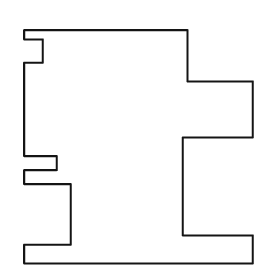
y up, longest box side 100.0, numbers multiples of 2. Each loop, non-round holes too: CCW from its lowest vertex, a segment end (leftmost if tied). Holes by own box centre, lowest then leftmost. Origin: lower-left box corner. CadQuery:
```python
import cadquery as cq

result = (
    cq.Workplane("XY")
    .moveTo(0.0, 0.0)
    .lineTo(98.0, 0.0)
    .lineTo(98.0, 12.0)
    .lineTo(68.0, 12.0)
    .lineTo(68.0, 54.0)
    .lineTo(98.0, 54.0)
    .lineTo(98.0, 78.0)
    .lineTo(70.0, 78.0)
    .lineTo(70.0, 100.0)
    .lineTo(0.0, 100.0)
    .lineTo(0.0, 96.0)
    .lineTo(8.0, 96.0)
    .lineTo(8.0, 86.0)
    .lineTo(0.0, 86.0)
    .lineTo(0.0, 46.0)
    .lineTo(14.0, 46.0)
    .lineTo(14.0, 40.0)
    .lineTo(0.0, 40.0)
    .lineTo(0.0, 34.0)
    .lineTo(20.0, 34.0)
    .lineTo(20.0, 8.0)
    .lineTo(0.0, 8.0)
    .close()
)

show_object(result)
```